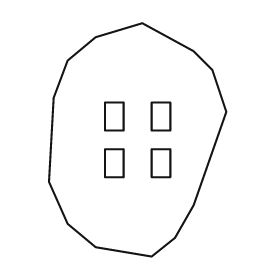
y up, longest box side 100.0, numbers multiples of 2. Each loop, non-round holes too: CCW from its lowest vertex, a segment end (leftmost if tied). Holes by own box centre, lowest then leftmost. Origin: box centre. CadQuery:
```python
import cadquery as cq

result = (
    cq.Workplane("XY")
    .moveTo(6.0, -50.0)
    .lineTo(16.0, -42.0)
    .lineTo(24.0, -28.0)
    .lineTo(38.0, 12.0)
    .lineTo(32.0, 30.0)
    .lineTo(24.0, 38.0)
    .lineTo(2.0, 50.0)
    .lineTo(-18.0, 44.0)
    .lineTo(-30.0, 34.0)
    .lineTo(-36.0, 18.0)
    .lineTo(-38.0, -18.0)
    .lineTo(-30.0, -36.0)
    .lineTo(-18.0, -46.0)
    .close()
    .moveTo(-14.0, -16.0)
    .lineTo(-6.0, -16.0)
    .lineTo(-6.0, -4.0)
    .lineTo(-14.0, -4.0)
    .close()
    .moveTo(6.0, -16.0)
    .lineTo(14.0, -16.0)
    .lineTo(14.0, -4.0)
    .lineTo(6.0, -4.0)
    .close()
    .moveTo(-14.0, 4.0)
    .lineTo(-6.0, 4.0)
    .lineTo(-6.0, 16.0)
    .lineTo(-14.0, 16.0)
    .close()
    .moveTo(6.0, 4.0)
    .lineTo(14.0, 4.0)
    .lineTo(14.0, 16.0)
    .lineTo(6.0, 16.0)
    .close()
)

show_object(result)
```